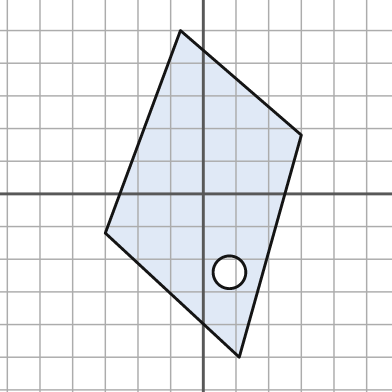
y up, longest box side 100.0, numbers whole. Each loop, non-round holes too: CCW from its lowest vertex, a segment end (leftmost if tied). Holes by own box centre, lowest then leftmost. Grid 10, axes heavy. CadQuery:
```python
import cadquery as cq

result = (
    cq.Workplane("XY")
    .moveTo(11.0, -50.0)
    .lineTo(30.0, 18.0)
    .lineTo(-7.0, 50.0)
    .lineTo(-30.0, -12.0)
    .close()
    .moveTo(8.0, -24.0)
    .circle(5.0)
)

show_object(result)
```